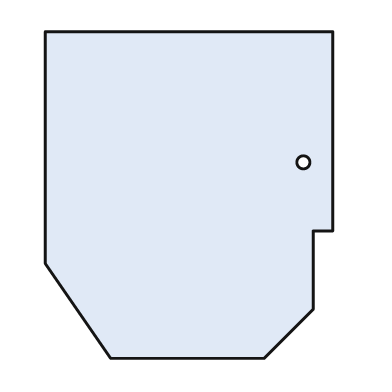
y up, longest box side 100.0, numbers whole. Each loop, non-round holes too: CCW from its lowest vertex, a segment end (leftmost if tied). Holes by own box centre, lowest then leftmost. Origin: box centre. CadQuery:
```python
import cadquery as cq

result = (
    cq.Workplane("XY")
    .moveTo(-24.0, -50.0)
    .lineTo(23.0, -50.0)
    .lineTo(38.0, -35.0)
    .lineTo(38.0, -11.0)
    .lineTo(44.0, -11.0)
    .lineTo(44.0, 50.0)
    .lineTo(-44.0, 50.0)
    .lineTo(-44.0, -21.0)
    .close()
    .moveTo(35.0, 10.0)
    .circle(2.0)
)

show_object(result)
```